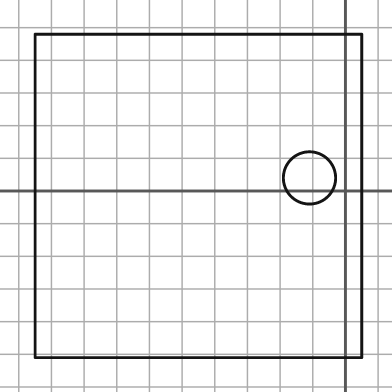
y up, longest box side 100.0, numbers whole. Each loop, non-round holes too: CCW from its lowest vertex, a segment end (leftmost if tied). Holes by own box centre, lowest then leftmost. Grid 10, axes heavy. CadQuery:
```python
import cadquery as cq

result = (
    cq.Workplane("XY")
    .moveTo(-95.0, -51.0)
    .lineTo(5.0, -51.0)
    .lineTo(5.0, 48.0)
    .lineTo(-95.0, 48.0)
    .close()
    .moveTo(-11.0, 4.0)
    .circle(8.0)
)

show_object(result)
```